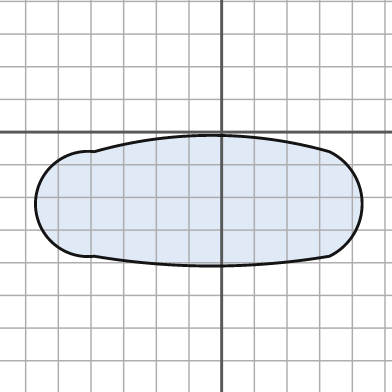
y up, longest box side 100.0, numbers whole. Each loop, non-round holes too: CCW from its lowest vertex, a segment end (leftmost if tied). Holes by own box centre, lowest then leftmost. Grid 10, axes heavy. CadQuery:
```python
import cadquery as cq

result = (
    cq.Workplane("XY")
    .moveTo(-39.0, -38.0)
    .threePointArc((-3.0, -41.0), (33.0, -38.0))
    .threePointArc((43.0, -22.0), (33.0, -6.0))
    .threePointArc((-3.0, -1.0), (-39.0, -6.0))
    .threePointArc((-57.0, -22.0), (-39.0, -38.0))
    .close()
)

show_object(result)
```